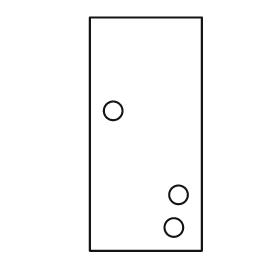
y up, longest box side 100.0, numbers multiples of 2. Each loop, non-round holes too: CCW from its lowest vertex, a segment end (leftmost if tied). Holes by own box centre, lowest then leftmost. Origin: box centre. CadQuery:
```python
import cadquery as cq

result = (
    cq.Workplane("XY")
    .moveTo(-24.0, -50.0)
    .lineTo(24.0, -50.0)
    .lineTo(24.0, 50.0)
    .lineTo(-24.0, 50.0)
    .close()
    .moveTo(12.0, -40.0)
    .circle(4.0)
    .moveTo(14.0, -26.0)
    .circle(4.0)
    .moveTo(-14.0, 10.0)
    .circle(4.0)
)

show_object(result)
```